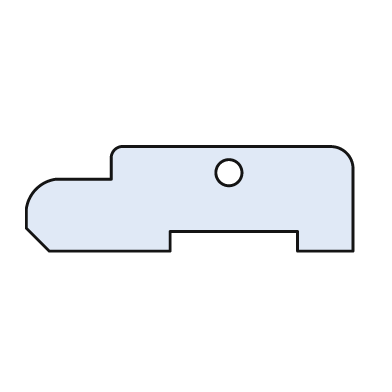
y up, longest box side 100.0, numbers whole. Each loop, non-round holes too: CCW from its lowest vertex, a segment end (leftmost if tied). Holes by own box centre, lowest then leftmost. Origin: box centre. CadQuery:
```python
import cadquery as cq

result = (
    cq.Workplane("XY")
    .moveTo(-43.0, -16.0)
    .lineTo(-6.0, -16.0)
    .lineTo(-6.0, -10.0)
    .lineTo(33.0, -10.0)
    .lineTo(33.0, -16.0)
    .lineTo(50.0, -16.0)
    .lineTo(50.0, 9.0)
    .threePointArc((48.0, 14.0), (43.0, 16.0))
    .lineTo(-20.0, 16.0)
    .threePointArc((-23.0, 15.0), (-24.0, 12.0))
    .lineTo(-24.0, 6.0)
    .lineTo(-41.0, 6.0)
    .threePointArc((-47.0, 3.0), (-50.0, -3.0))
    .lineTo(-50.0, -9.0)
    .close()
    .moveTo(12.0, 8.0)
    .circle(4.0)
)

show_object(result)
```